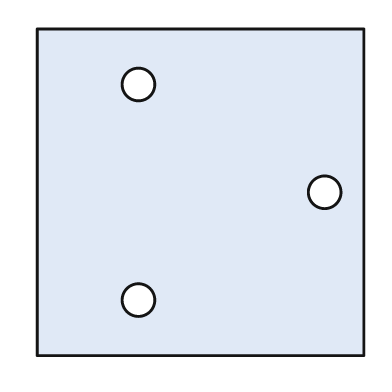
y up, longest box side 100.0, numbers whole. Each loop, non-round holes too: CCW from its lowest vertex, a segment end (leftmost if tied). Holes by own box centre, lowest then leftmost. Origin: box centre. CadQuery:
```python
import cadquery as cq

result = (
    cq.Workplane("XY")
    .moveTo(-50.0, -50.0)
    .lineTo(50.0, -50.0)
    .lineTo(50.0, 50.0)
    .lineTo(-50.0, 50.0)
    .close()
    .moveTo(-19.0, -33.0)
    .circle(5.0)
    .moveTo(38.0, 0.0)
    .circle(5.0)
    .moveTo(-19.0, 33.0)
    .circle(5.0)
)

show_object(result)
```